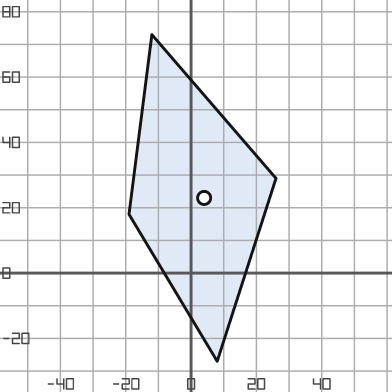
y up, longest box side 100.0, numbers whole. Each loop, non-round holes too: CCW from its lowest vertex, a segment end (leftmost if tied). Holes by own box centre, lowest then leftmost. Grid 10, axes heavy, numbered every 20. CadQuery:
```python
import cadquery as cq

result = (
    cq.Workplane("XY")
    .moveTo(8.0, -27.0)
    .lineTo(26.0, 29.0)
    .lineTo(-12.0, 73.0)
    .lineTo(-19.0, 18.0)
    .close()
    .moveTo(4.0, 23.0)
    .circle(2.0)
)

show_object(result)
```